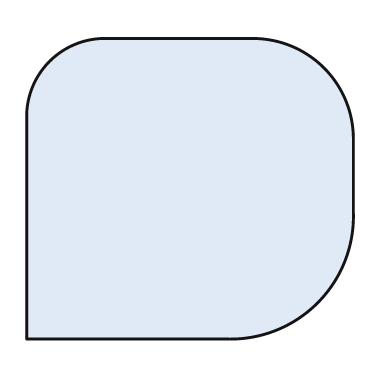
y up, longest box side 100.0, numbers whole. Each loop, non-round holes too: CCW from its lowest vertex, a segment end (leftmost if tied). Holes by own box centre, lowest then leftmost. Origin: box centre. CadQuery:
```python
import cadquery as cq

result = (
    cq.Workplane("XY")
    .moveTo(-50.0, -46.0)
    .lineTo(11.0, -46.0)
    .threePointArc((39.0, -35.0), (50.0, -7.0))
    .lineTo(50.0, 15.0)
    .threePointArc((41.0, 37.0), (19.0, 46.0))
    .lineTo(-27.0, 46.0)
    .threePointArc((-43.0, 39.0), (-50.0, 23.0))
    .close()
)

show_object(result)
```